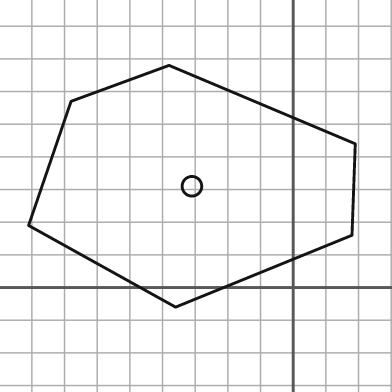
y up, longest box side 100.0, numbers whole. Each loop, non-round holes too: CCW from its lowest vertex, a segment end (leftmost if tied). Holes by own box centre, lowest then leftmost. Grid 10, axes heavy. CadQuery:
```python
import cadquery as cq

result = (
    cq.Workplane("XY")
    .moveTo(-36.0, -6.0)
    .lineTo(18.0, 16.0)
    .lineTo(19.0, 44.0)
    .lineTo(-38.0, 68.0)
    .lineTo(-68.0, 57.0)
    .lineTo(-81.0, 19.0)
    .close()
    .moveTo(-31.0, 31.0)
    .circle(3.0)
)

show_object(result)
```